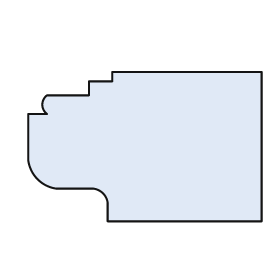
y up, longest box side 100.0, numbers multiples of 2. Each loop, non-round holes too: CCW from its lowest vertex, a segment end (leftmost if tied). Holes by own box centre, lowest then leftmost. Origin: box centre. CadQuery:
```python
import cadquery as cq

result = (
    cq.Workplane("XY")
    .moveTo(-16.0, -32.0)
    .lineTo(50.0, -32.0)
    .lineTo(50.0, 32.0)
    .lineTo(-14.0, 32.0)
    .lineTo(-14.0, 28.0)
    .lineTo(-24.0, 28.0)
    .lineTo(-24.0, 22.0)
    .lineTo(-42.0, 22.0)
    .threePointArc((-44.0, 18.0), (-42.0, 14.0))
    .lineTo(-50.0, 14.0)
    .lineTo(-50.0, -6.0)
    .threePointArc((-46.0, -14.0), (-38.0, -18.0))
    .lineTo(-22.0, -18.0)
    .threePointArc((-18.0, -20.0), (-16.0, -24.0))
    .close()
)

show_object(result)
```